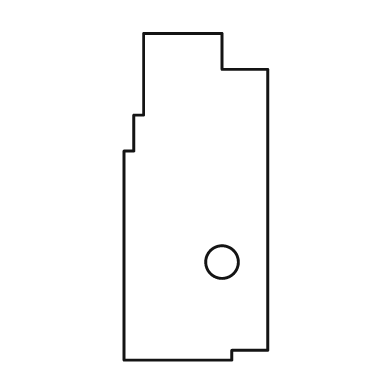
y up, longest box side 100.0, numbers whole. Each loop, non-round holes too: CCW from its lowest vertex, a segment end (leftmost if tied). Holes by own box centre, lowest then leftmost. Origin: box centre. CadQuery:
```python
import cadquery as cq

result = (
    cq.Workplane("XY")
    .moveTo(-22.0, -50.0)
    .lineTo(11.0, -50.0)
    .lineTo(11.0, -47.0)
    .lineTo(22.0, -47.0)
    .lineTo(22.0, 39.0)
    .lineTo(8.0, 39.0)
    .lineTo(8.0, 50.0)
    .lineTo(-16.0, 50.0)
    .lineTo(-16.0, 25.0)
    .lineTo(-19.0, 25.0)
    .lineTo(-19.0, 14.0)
    .lineTo(-22.0, 14.0)
    .close()
    .moveTo(8.0, -20.0)
    .circle(5.0)
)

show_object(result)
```